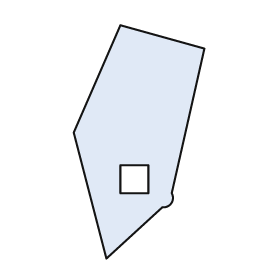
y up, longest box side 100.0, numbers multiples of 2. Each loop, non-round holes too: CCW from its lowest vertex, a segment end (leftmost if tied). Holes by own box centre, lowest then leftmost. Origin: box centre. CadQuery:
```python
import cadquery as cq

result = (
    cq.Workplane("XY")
    .moveTo(-14.0, -50.0)
    .lineTo(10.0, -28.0)
    .threePointArc((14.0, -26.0), (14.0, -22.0))
    .lineTo(28.0, 40.0)
    .lineTo(-8.0, 50.0)
    .lineTo(-28.0, 4.0)
    .close()
    .moveTo(-8.0, -22.0)
    .lineTo(4.0, -22.0)
    .lineTo(4.0, -10.0)
    .lineTo(-8.0, -10.0)
    .close()
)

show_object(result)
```